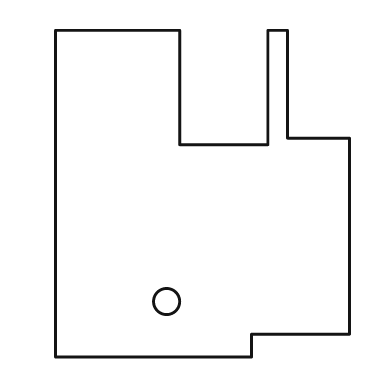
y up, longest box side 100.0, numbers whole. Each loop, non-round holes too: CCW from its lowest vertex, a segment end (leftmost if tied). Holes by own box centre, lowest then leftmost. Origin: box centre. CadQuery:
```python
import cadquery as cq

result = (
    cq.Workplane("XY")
    .moveTo(-45.0, -50.0)
    .lineTo(15.0, -50.0)
    .lineTo(15.0, -43.0)
    .lineTo(45.0, -43.0)
    .lineTo(45.0, 17.0)
    .lineTo(26.0, 17.0)
    .lineTo(26.0, 50.0)
    .lineTo(20.0, 50.0)
    .lineTo(20.0, 15.0)
    .lineTo(-7.0, 15.0)
    .lineTo(-7.0, 50.0)
    .lineTo(-45.0, 50.0)
    .close()
    .moveTo(-11.0, -33.0)
    .circle(4.0)
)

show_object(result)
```